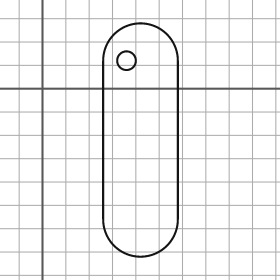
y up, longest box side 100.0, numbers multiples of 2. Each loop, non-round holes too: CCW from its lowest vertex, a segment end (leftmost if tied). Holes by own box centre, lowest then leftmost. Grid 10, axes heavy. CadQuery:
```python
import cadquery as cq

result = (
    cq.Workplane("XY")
    .moveTo(26.0, -56.0)
    .threePointArc((42.0, -72.0), (58.0, -56.0))
    .lineTo(58.0, 12.0)
    .threePointArc((42.0, 28.0), (26.0, 12.0))
    .close()
    .moveTo(36.0, 12.0)
    .circle(4.0)
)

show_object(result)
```